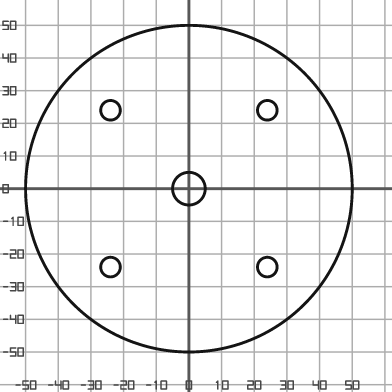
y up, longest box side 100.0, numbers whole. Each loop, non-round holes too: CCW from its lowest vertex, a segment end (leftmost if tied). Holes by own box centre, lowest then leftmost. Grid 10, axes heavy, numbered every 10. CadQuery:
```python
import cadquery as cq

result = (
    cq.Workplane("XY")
    .moveTo(0.0, 0.0)
    .circle(50.0)
    .moveTo(-24.0, -24.0)
    .circle(3.0)
    .moveTo(24.0, -24.0)
    .circle(3.0)
    .moveTo(0.0, 0.0)
    .circle(5.0)
    .moveTo(-24.0, 24.0)
    .circle(3.0)
    .moveTo(24.0, 24.0)
    .circle(3.0)
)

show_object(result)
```